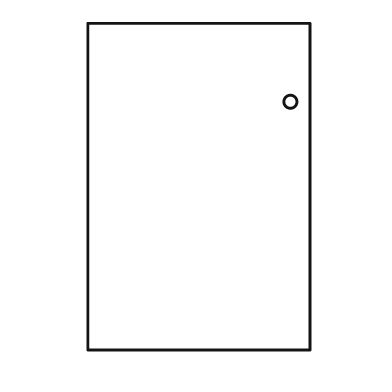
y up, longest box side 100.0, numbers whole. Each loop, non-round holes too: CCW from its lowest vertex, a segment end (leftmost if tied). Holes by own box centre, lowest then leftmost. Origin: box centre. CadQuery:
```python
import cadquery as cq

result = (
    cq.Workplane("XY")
    .moveTo(-34.0, -50.0)
    .lineTo(34.0, -50.0)
    .lineTo(34.0, 50.0)
    .lineTo(-34.0, 50.0)
    .close()
    .moveTo(28.0, 26.0)
    .circle(2.0)
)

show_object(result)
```